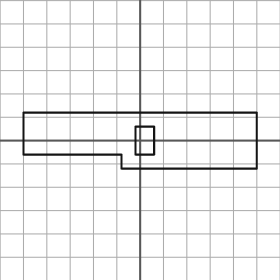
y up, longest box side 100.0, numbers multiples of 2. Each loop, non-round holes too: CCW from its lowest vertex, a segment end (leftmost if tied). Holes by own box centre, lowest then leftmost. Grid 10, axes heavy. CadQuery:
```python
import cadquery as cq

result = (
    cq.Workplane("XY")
    .moveTo(-8.0, -12.0)
    .lineTo(50.0, -12.0)
    .lineTo(50.0, 12.0)
    .lineTo(-50.0, 12.0)
    .lineTo(-50.0, -6.0)
    .lineTo(-8.0, -6.0)
    .close()
    .moveTo(-2.0, -6.0)
    .lineTo(6.0, -6.0)
    .lineTo(6.0, 6.0)
    .lineTo(-2.0, 6.0)
    .close()
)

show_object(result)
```